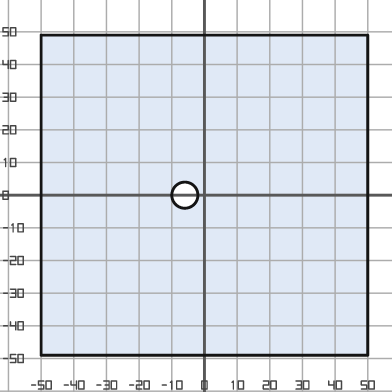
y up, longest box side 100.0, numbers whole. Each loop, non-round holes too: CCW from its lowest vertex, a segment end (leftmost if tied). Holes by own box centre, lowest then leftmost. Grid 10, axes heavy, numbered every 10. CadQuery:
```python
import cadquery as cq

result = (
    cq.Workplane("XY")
    .moveTo(-50.0, -49.0)
    .lineTo(50.0, -49.0)
    .lineTo(50.0, 49.0)
    .lineTo(-50.0, 49.0)
    .close()
    .moveTo(-6.0, 0.0)
    .circle(4.0)
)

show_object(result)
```